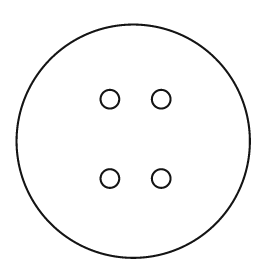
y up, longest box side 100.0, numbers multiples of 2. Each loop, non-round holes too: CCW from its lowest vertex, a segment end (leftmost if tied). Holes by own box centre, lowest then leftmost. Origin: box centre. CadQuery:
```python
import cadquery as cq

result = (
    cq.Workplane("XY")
    .moveTo(0.0, 0.0)
    .circle(50.0)
    .moveTo(-10.0, -16.0)
    .circle(4.0)
    .moveTo(12.0, -16.0)
    .circle(4.0)
    .moveTo(-10.0, 18.0)
    .circle(4.0)
    .moveTo(12.0, 18.0)
    .circle(4.0)
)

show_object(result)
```